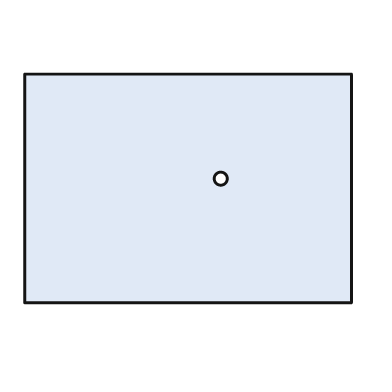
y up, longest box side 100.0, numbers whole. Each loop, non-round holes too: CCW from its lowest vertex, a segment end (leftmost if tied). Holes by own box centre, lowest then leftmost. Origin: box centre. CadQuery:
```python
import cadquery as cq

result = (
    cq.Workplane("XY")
    .moveTo(-50.0, -35.0)
    .lineTo(50.0, -35.0)
    .lineTo(50.0, 35.0)
    .lineTo(-50.0, 35.0)
    .close()
    .moveTo(10.0, 3.0)
    .circle(2.0)
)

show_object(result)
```